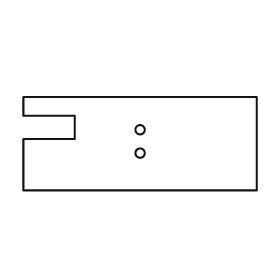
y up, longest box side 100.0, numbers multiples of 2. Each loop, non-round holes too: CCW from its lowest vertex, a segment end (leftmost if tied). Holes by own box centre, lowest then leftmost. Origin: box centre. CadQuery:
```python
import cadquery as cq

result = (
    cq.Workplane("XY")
    .moveTo(-50.0, -20.0)
    .lineTo(50.0, -20.0)
    .lineTo(50.0, 20.0)
    .lineTo(-50.0, 20.0)
    .lineTo(-50.0, 12.0)
    .lineTo(-28.0, 12.0)
    .lineTo(-28.0, 2.0)
    .lineTo(-50.0, 2.0)
    .close()
    .moveTo(0.0, -4.0)
    .circle(2.0)
    .moveTo(0.0, 6.0)
    .circle(2.0)
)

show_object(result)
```